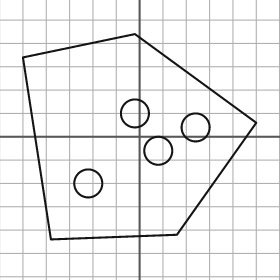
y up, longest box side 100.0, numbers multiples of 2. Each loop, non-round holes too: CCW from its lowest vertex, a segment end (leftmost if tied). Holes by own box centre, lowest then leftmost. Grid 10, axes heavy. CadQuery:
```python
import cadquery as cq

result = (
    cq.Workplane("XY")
    .moveTo(-38.0, -44.0)
    .lineTo(16.0, -42.0)
    .lineTo(50.0, 6.0)
    .lineTo(-2.0, 44.0)
    .lineTo(-50.0, 34.0)
    .close()
    .moveTo(-22.0, -20.0)
    .circle(6.0)
    .moveTo(8.0, -6.0)
    .circle(6.0)
    .moveTo(24.0, 4.0)
    .circle(6.0)
    .moveTo(-2.0, 10.0)
    .circle(6.0)
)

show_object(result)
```